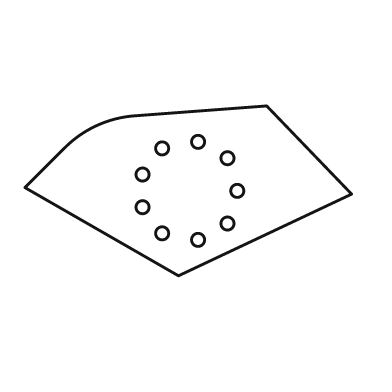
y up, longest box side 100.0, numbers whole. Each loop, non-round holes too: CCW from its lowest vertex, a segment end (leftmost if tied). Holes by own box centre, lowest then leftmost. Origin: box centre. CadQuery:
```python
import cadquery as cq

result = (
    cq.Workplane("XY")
    .moveTo(-3.0, -26.0)
    .lineTo(50.0, -1.0)
    .lineTo(24.0, 26.0)
    .lineTo(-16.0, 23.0)
    .threePointArc((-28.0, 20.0), (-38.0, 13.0))
    .lineTo(-50.0, 1.0)
    .close()
    .moveTo(3.0, -15.0)
    .circle(2.0)
    .moveTo(-8.0, -13.0)
    .circle(2.0)
    .moveTo(12.0, -10.0)
    .circle(2.0)
    .moveTo(-14.0, -5.0)
    .circle(2.0)
    .moveTo(15.0, 0.0)
    .circle(2.0)
    .moveTo(-14.0, 5.0)
    .circle(2.0)
    .moveTo(12.0, 10.0)
    .circle(2.0)
    .moveTo(-8.0, 13.0)
    .circle(2.0)
    .moveTo(3.0, 15.0)
    .circle(2.0)
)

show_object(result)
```